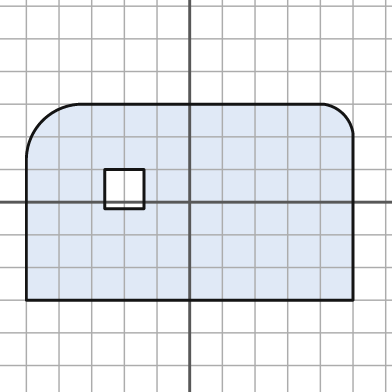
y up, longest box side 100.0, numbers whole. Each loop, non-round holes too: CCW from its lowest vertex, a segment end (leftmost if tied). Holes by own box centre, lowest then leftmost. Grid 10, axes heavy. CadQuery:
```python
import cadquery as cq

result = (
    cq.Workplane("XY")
    .moveTo(-50.0, -30.0)
    .lineTo(50.0, -30.0)
    .lineTo(50.0, 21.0)
    .threePointArc((47.0, 27.0), (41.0, 30.0))
    .lineTo(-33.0, 30.0)
    .threePointArc((-45.0, 25.0), (-50.0, 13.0))
    .close()
    .moveTo(-26.0, -2.0)
    .lineTo(-14.0, -2.0)
    .lineTo(-14.0, 10.0)
    .lineTo(-26.0, 10.0)
    .close()
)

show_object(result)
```